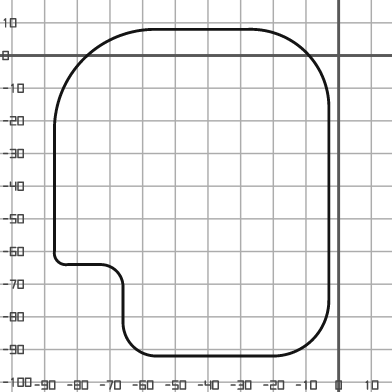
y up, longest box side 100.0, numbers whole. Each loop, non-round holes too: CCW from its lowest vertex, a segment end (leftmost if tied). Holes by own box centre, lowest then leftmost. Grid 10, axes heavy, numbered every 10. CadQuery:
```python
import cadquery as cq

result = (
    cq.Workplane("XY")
    .moveTo(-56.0, -92.0)
    .lineTo(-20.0, -92.0)
    .threePointArc((-8.0, -87.0), (-3.0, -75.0))
    .lineTo(-3.0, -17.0)
    .threePointArc((-10.0, 1.0), (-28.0, 8.0))
    .lineTo(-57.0, 8.0)
    .threePointArc((-78.0, -1.0), (-87.0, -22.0))
    .lineTo(-87.0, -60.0)
    .threePointArc((-86.0, -63.0), (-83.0, -64.0))
    .lineTo(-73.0, -64.0)
    .threePointArc((-68.0, -66.0), (-66.0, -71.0))
    .lineTo(-66.0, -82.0)
    .threePointArc((-63.0, -89.0), (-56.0, -92.0))
    .close()
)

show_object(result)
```